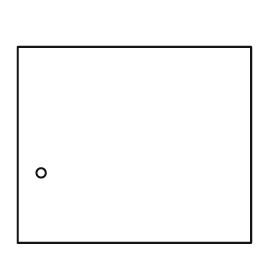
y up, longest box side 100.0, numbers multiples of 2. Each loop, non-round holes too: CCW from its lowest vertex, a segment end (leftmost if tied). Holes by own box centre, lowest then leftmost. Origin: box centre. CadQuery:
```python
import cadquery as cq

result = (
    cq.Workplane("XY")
    .moveTo(-50.0, -42.0)
    .lineTo(50.0, -42.0)
    .lineTo(50.0, 42.0)
    .lineTo(-50.0, 42.0)
    .close()
    .moveTo(-40.0, -12.0)
    .circle(2.0)
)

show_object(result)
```